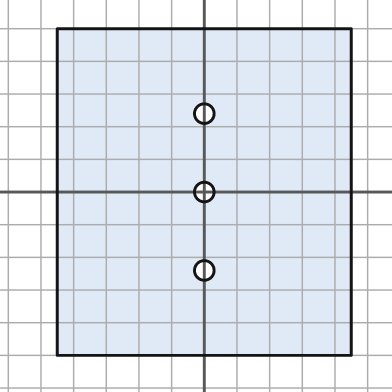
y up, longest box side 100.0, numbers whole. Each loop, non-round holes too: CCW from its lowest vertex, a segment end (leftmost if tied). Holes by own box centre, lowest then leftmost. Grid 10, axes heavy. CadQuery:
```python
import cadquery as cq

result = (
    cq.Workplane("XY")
    .moveTo(-45.0, -50.0)
    .lineTo(45.0, -50.0)
    .lineTo(45.0, 50.0)
    .lineTo(-45.0, 50.0)
    .close()
    .moveTo(0.0, -24.0)
    .circle(3.0)
    .moveTo(0.0, 0.0)
    .circle(3.0)
    .moveTo(0.0, 24.0)
    .circle(3.0)
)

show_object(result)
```